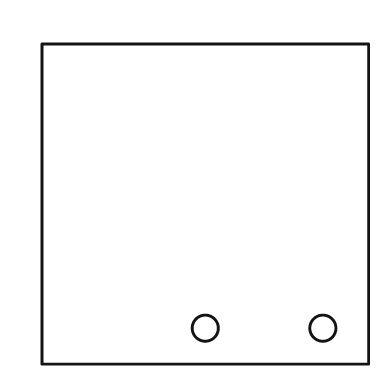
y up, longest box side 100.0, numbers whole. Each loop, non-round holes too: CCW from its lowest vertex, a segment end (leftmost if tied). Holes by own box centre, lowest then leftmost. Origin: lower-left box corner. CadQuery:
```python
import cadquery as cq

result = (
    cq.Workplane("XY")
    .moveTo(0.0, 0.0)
    .lineTo(100.0, 0.0)
    .lineTo(100.0, 98.0)
    .lineTo(0.0, 98.0)
    .close()
    .moveTo(50.0, 11.0)
    .circle(4.0)
    .moveTo(86.0, 11.0)
    .circle(4.0)
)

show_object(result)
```